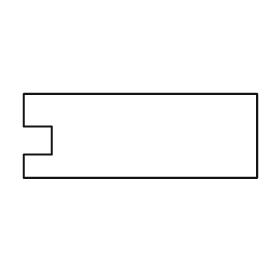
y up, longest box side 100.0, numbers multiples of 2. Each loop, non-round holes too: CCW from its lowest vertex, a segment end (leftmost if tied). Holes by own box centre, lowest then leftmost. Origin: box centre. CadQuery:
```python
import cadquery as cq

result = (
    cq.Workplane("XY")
    .moveTo(-50.0, -18.0)
    .lineTo(50.0, -18.0)
    .lineTo(50.0, 18.0)
    .lineTo(-50.0, 18.0)
    .lineTo(-50.0, 4.0)
    .lineTo(-38.0, 4.0)
    .lineTo(-38.0, -8.0)
    .lineTo(-50.0, -8.0)
    .close()
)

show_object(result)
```